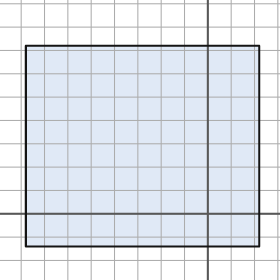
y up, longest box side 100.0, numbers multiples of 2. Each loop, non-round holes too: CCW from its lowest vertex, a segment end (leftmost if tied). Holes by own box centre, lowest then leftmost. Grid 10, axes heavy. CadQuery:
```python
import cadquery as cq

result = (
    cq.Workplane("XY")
    .moveTo(-78.0, -14.0)
    .lineTo(22.0, -14.0)
    .lineTo(22.0, 72.0)
    .lineTo(-78.0, 72.0)
    .close()
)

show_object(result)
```